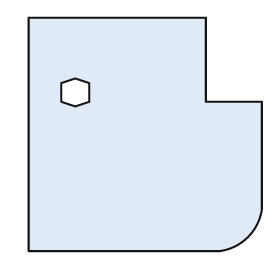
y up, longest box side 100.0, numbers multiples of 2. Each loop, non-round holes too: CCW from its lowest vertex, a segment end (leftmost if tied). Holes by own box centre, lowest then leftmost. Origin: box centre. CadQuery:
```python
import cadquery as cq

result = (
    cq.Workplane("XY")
    .moveTo(-50.0, -50.0)
    .lineTo(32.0, -50.0)
    .threePointArc((44.0, -44.0), (50.0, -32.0))
    .lineTo(50.0, 14.0)
    .lineTo(26.0, 14.0)
    .lineTo(26.0, 50.0)
    .lineTo(-50.0, 50.0)
    .close()
    .moveTo(-30.0, 12.0)
    .lineTo(-24.0, 14.0)
    .lineTo(-24.0, 22.0)
    .lineTo(-30.0, 24.0)
    .lineTo(-36.0, 22.0)
    .lineTo(-36.0, 14.0)
    .close()
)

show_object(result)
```